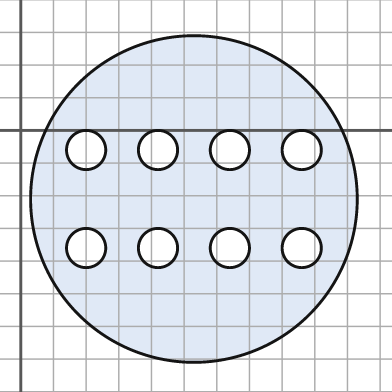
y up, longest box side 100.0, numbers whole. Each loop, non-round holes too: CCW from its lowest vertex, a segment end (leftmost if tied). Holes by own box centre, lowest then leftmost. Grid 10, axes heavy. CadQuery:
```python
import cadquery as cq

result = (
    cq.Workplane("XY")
    .moveTo(53.0, -21.0)
    .circle(50.0)
    .moveTo(20.0, -36.0)
    .circle(6.0)
    .moveTo(42.0, -36.0)
    .circle(6.0)
    .moveTo(64.0, -36.0)
    .circle(6.0)
    .moveTo(86.0, -36.0)
    .circle(6.0)
    .moveTo(20.0, -6.0)
    .circle(6.0)
    .moveTo(42.0, -6.0)
    .circle(6.0)
    .moveTo(64.0, -6.0)
    .circle(6.0)
    .moveTo(86.0, -6.0)
    .circle(6.0)
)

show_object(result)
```